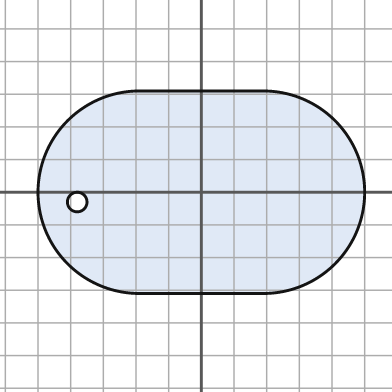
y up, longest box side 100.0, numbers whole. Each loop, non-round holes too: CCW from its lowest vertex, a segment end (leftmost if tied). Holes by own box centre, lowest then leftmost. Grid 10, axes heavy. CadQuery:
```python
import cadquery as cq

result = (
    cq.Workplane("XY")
    .moveTo(-19.0, -31.0)
    .lineTo(19.0, -31.0)
    .threePointArc((50.0, 0.0), (19.0, 31.0))
    .lineTo(-19.0, 31.0)
    .threePointArc((-50.0, 0.0), (-19.0, -31.0))
    .close()
    .moveTo(-38.0, -3.0)
    .circle(3.0)
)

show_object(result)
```